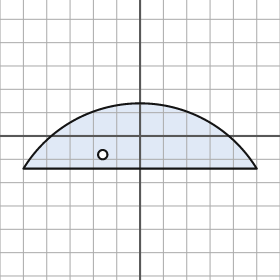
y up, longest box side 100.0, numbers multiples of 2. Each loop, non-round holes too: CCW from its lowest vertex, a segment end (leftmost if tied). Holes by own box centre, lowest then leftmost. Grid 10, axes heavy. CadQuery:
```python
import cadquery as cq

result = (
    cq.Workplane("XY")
    .moveTo(-50.0, -14.0)
    .lineTo(50.0, -14.0)
    .threePointArc((0.0, 14.0), (-50.0, -14.0))
    .close()
    .moveTo(-16.0, -8.0)
    .circle(2.0)
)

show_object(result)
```